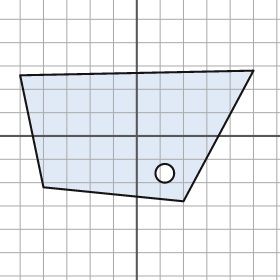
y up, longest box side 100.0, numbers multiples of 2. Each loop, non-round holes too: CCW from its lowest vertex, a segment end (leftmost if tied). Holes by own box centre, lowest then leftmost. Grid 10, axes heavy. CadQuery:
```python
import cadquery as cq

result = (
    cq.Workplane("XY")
    .moveTo(20.0, -28.0)
    .lineTo(50.0, 28.0)
    .lineTo(-50.0, 26.0)
    .lineTo(-40.0, -22.0)
    .close()
    .moveTo(12.0, -16.0)
    .circle(4.0)
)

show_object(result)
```